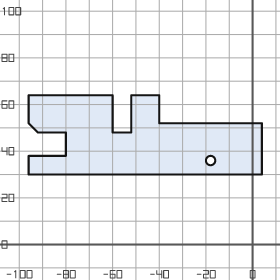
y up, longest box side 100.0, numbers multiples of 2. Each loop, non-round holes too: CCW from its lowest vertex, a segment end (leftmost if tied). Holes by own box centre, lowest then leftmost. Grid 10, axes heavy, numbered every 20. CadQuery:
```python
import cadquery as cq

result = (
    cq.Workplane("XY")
    .moveTo(-96.0, 30.0)
    .lineTo(4.0, 30.0)
    .lineTo(4.0, 52.0)
    .lineTo(-40.0, 52.0)
    .lineTo(-40.0, 64.0)
    .lineTo(-52.0, 64.0)
    .lineTo(-52.0, 48.0)
    .lineTo(-60.0, 48.0)
    .lineTo(-60.0, 64.0)
    .lineTo(-96.0, 64.0)
    .lineTo(-96.0, 52.0)
    .lineTo(-92.0, 48.0)
    .lineTo(-80.0, 48.0)
    .lineTo(-80.0, 38.0)
    .lineTo(-96.0, 38.0)
    .close()
    .moveTo(-18.0, 36.0)
    .circle(2.0)
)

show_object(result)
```